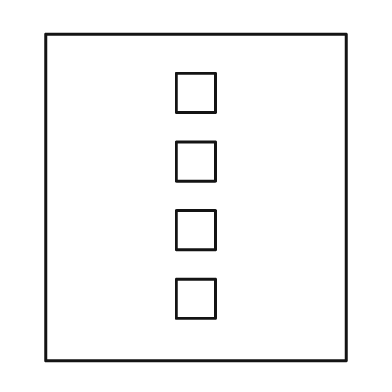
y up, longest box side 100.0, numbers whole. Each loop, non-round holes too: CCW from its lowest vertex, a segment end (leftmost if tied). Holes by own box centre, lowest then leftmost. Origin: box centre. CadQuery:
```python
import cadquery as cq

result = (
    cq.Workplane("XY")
    .moveTo(-46.0, -50.0)
    .lineTo(46.0, -50.0)
    .lineTo(46.0, 50.0)
    .lineTo(-46.0, 50.0)
    .close()
    .moveTo(-6.0, -37.0)
    .lineTo(6.0, -37.0)
    .lineTo(6.0, -25.0)
    .lineTo(-6.0, -25.0)
    .close()
    .moveTo(-6.0, -16.0)
    .lineTo(6.0, -16.0)
    .lineTo(6.0, -4.0)
    .lineTo(-6.0, -4.0)
    .close()
    .moveTo(-6.0, 5.0)
    .lineTo(6.0, 5.0)
    .lineTo(6.0, 17.0)
    .lineTo(-6.0, 17.0)
    .close()
    .moveTo(-6.0, 26.0)
    .lineTo(6.0, 26.0)
    .lineTo(6.0, 38.0)
    .lineTo(-6.0, 38.0)
    .close()
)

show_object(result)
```